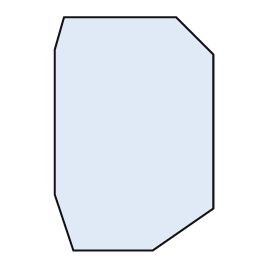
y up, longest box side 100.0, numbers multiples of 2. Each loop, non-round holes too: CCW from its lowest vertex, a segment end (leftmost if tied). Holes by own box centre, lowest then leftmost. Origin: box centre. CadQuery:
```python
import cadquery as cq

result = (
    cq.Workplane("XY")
    .moveTo(-26.0, -50.0)
    .lineTo(8.0, -50.0)
    .lineTo(34.0, -32.0)
    .lineTo(34.0, 34.0)
    .lineTo(18.0, 50.0)
    .lineTo(-30.0, 50.0)
    .lineTo(-34.0, 36.0)
    .lineTo(-34.0, -26.0)
    .close()
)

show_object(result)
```